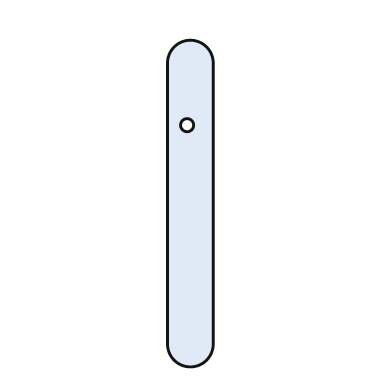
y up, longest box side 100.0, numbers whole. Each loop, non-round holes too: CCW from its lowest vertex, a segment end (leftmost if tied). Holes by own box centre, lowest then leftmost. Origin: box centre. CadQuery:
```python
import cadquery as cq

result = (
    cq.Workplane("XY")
    .moveTo(-7.0, -43.0)
    .threePointArc((0.0, -50.0), (7.0, -43.0))
    .lineTo(7.0, 43.0)
    .threePointArc((0.0, 50.0), (-7.0, 43.0))
    .close()
    .moveTo(-1.0, 24.0)
    .circle(2.0)
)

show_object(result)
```